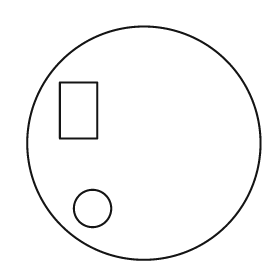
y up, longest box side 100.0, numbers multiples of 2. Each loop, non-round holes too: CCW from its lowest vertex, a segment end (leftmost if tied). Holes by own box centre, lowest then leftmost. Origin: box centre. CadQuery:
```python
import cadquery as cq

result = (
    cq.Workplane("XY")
    .moveTo(0.0, 0.0)
    .circle(50.0)
    .moveTo(-22.0, -28.0)
    .circle(8.0)
    .moveTo(-36.0, 2.0)
    .lineTo(-20.0, 2.0)
    .lineTo(-20.0, 26.0)
    .lineTo(-36.0, 26.0)
    .close()
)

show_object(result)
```